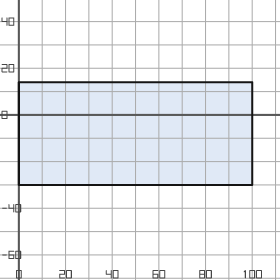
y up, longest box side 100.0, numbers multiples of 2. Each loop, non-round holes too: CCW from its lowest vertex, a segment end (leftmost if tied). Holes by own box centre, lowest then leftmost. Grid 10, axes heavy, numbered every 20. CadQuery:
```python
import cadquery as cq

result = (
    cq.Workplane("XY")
    .moveTo(0.0, -30.0)
    .lineTo(100.0, -30.0)
    .lineTo(100.0, 14.0)
    .lineTo(0.0, 14.0)
    .close()
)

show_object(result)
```